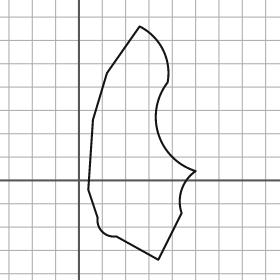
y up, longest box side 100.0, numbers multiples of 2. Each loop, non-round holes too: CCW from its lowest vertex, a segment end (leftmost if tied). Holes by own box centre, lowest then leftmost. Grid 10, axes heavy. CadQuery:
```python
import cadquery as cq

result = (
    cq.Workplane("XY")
    .moveTo(34.0, -34.0)
    .lineTo(44.0, -14.0)
    .threePointArc((44.0, -4.0), (50.0, 4.0))
    .threePointArc((34.0, 20.0), (38.0, 42.0))
    .threePointArc((36.0, 56.0), (26.0, 66.0))
    .lineTo(12.0, 46.0)
    .lineTo(6.0, 26.0)
    .lineTo(4.0, -4.0)
    .lineTo(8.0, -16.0)
    .threePointArc((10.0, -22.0), (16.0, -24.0))
    .close()
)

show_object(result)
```